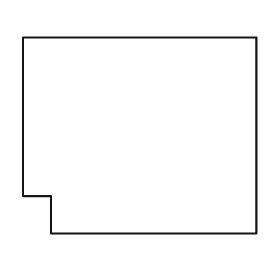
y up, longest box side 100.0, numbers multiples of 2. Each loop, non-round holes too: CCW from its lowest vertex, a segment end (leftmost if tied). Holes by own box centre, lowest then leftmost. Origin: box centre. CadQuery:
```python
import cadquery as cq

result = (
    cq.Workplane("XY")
    .moveTo(-38.0, -42.0)
    .lineTo(50.0, -42.0)
    .lineTo(50.0, 42.0)
    .lineTo(-50.0, 42.0)
    .lineTo(-50.0, -26.0)
    .lineTo(-38.0, -26.0)
    .close()
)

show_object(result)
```